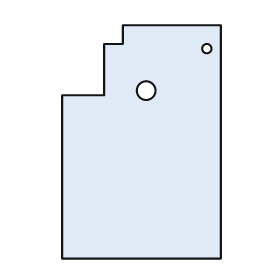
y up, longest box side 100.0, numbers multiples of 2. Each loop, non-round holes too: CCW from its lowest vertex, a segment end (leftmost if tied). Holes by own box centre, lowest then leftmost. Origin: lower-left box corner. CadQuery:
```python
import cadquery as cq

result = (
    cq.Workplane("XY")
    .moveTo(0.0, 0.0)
    .lineTo(68.0, 0.0)
    .lineTo(68.0, 100.0)
    .lineTo(26.0, 100.0)
    .lineTo(26.0, 92.0)
    .lineTo(18.0, 92.0)
    .lineTo(18.0, 70.0)
    .lineTo(0.0, 70.0)
    .close()
    .moveTo(36.0, 72.0)
    .circle(4.0)
    .moveTo(62.0, 90.0)
    .circle(2.0)
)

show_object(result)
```